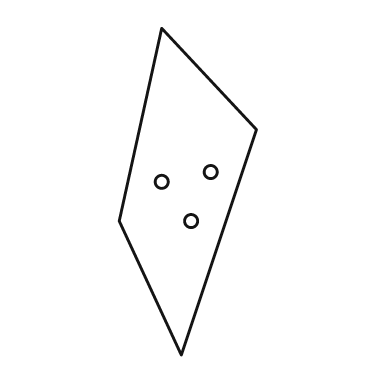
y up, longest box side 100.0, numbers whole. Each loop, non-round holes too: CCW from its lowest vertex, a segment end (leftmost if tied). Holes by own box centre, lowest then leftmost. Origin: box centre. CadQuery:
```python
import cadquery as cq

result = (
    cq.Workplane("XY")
    .moveTo(-2.0, -50.0)
    .lineTo(21.0, 19.0)
    .lineTo(-8.0, 50.0)
    .lineTo(-21.0, -9.0)
    .close()
    .moveTo(1.0, -9.0)
    .circle(2.0)
    .moveTo(-8.0, 3.0)
    .circle(2.0)
    .moveTo(7.0, 6.0)
    .circle(2.0)
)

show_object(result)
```